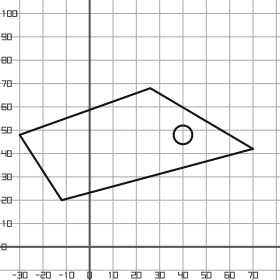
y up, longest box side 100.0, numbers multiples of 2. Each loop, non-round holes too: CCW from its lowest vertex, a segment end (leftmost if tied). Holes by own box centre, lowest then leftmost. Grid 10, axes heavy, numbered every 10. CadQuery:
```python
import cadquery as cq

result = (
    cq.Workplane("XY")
    .moveTo(-12.0, 20.0)
    .lineTo(70.0, 42.0)
    .lineTo(26.0, 68.0)
    .lineTo(-30.0, 48.0)
    .close()
    .moveTo(40.0, 48.0)
    .circle(4.0)
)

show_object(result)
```